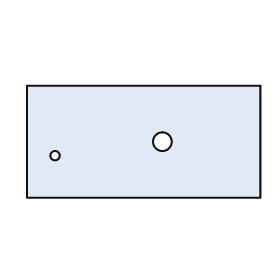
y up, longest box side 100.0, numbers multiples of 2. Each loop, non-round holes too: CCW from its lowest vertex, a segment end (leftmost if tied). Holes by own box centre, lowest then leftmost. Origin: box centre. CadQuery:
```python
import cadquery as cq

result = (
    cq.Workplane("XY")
    .moveTo(-50.0, -24.0)
    .lineTo(50.0, -24.0)
    .lineTo(50.0, 24.0)
    .lineTo(-50.0, 24.0)
    .close()
    .moveTo(-38.0, -6.0)
    .circle(2.0)
    .moveTo(8.0, 0.0)
    .circle(4.0)
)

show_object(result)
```